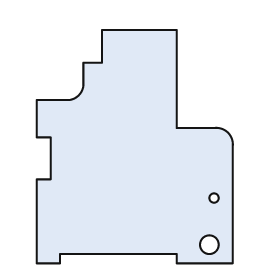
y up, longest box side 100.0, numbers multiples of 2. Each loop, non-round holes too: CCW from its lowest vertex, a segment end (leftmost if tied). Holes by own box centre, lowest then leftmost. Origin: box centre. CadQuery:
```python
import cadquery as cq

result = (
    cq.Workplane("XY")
    .moveTo(-42.0, -50.0)
    .lineTo(-32.0, -50.0)
    .lineTo(-32.0, -46.0)
    .lineTo(18.0, -46.0)
    .lineTo(18.0, -50.0)
    .lineTo(42.0, -50.0)
    .lineTo(42.0, 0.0)
    .threePointArc((40.0, 6.0), (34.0, 8.0))
    .lineTo(18.0, 8.0)
    .lineTo(18.0, 50.0)
    .lineTo(-14.0, 50.0)
    .lineTo(-14.0, 36.0)
    .lineTo(-22.0, 36.0)
    .lineTo(-22.0, 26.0)
    .threePointArc((-24.0, 22.0), (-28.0, 20.0))
    .lineTo(-42.0, 20.0)
    .lineTo(-42.0, 4.0)
    .lineTo(-36.0, 4.0)
    .lineTo(-36.0, -14.0)
    .lineTo(-42.0, -14.0)
    .close()
    .moveTo(32.0, -42.0)
    .circle(4.0)
    .moveTo(34.0, -22.0)
    .circle(2.0)
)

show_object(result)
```